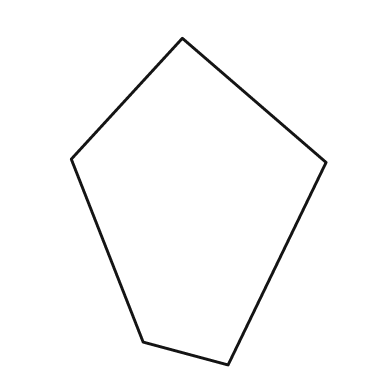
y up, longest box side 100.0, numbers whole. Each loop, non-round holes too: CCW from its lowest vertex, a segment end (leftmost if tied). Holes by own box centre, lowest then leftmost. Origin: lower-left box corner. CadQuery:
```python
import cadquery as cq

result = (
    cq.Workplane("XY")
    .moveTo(48.0, 0.0)
    .lineTo(78.0, 62.0)
    .lineTo(34.0, 100.0)
    .lineTo(0.0, 63.0)
    .lineTo(22.0, 7.0)
    .close()
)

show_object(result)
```